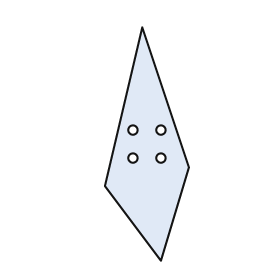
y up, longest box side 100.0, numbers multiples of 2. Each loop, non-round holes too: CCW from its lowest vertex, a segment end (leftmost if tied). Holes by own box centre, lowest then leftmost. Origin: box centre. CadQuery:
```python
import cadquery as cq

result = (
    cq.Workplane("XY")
    .moveTo(6.0, -50.0)
    .lineTo(18.0, -10.0)
    .lineTo(-2.0, 50.0)
    .lineTo(-18.0, -18.0)
    .close()
    .moveTo(-6.0, -6.0)
    .circle(2.0)
    .moveTo(6.0, -6.0)
    .circle(2.0)
    .moveTo(-6.0, 6.0)
    .circle(2.0)
    .moveTo(6.0, 6.0)
    .circle(2.0)
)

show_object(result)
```